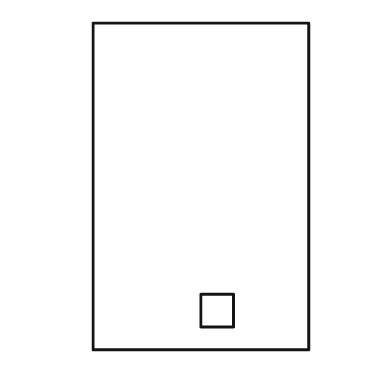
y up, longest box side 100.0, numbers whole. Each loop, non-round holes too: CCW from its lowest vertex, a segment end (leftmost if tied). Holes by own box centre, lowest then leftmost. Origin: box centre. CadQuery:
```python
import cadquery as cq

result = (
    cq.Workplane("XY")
    .moveTo(-33.0, -50.0)
    .lineTo(33.0, -50.0)
    .lineTo(33.0, 50.0)
    .lineTo(-33.0, 50.0)
    .close()
    .moveTo(0.0, -43.0)
    .lineTo(10.0, -43.0)
    .lineTo(10.0, -33.0)
    .lineTo(0.0, -33.0)
    .close()
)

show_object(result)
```